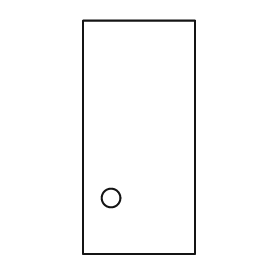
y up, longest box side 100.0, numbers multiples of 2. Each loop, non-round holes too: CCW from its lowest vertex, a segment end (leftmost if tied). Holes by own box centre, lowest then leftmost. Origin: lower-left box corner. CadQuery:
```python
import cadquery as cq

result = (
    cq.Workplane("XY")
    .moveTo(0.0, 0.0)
    .lineTo(48.0, 0.0)
    .lineTo(48.0, 100.0)
    .lineTo(0.0, 100.0)
    .close()
    .moveTo(12.0, 24.0)
    .circle(4.0)
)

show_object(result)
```